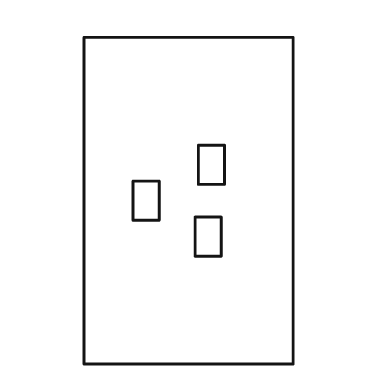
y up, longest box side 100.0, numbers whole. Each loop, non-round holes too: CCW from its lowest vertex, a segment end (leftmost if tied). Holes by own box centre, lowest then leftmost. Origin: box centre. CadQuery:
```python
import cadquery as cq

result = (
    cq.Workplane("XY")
    .moveTo(-32.0, -50.0)
    .lineTo(32.0, -50.0)
    .lineTo(32.0, 50.0)
    .lineTo(-32.0, 50.0)
    .close()
    .moveTo(2.0, -17.0)
    .lineTo(10.0, -17.0)
    .lineTo(10.0, -5.0)
    .lineTo(2.0, -5.0)
    .close()
    .moveTo(-17.0, -6.0)
    .lineTo(-9.0, -6.0)
    .lineTo(-9.0, 6.0)
    .lineTo(-17.0, 6.0)
    .close()
    .moveTo(3.0, 5.0)
    .lineTo(11.0, 5.0)
    .lineTo(11.0, 17.0)
    .lineTo(3.0, 17.0)
    .close()
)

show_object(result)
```